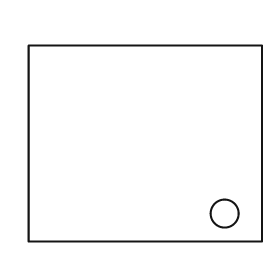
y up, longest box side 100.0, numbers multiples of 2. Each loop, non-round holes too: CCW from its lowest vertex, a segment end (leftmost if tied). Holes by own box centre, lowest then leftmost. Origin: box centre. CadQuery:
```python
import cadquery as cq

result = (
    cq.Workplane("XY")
    .moveTo(-50.0, -42.0)
    .lineTo(50.0, -42.0)
    .lineTo(50.0, 42.0)
    .lineTo(-50.0, 42.0)
    .close()
    .moveTo(34.0, -30.0)
    .circle(6.0)
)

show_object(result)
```